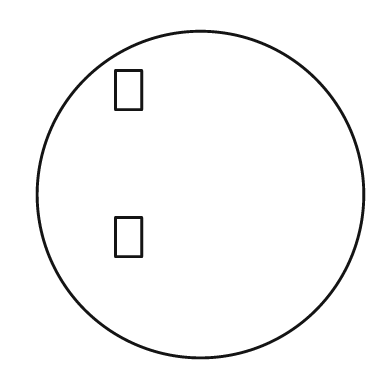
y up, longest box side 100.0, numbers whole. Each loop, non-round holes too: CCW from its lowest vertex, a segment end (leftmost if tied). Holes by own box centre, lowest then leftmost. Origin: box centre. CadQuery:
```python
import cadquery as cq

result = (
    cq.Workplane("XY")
    .moveTo(0.0, 0.0)
    .circle(50.0)
    .moveTo(-26.0, -19.0)
    .lineTo(-18.0, -19.0)
    .lineTo(-18.0, -7.0)
    .lineTo(-26.0, -7.0)
    .close()
    .moveTo(-26.0, 26.0)
    .lineTo(-18.0, 26.0)
    .lineTo(-18.0, 38.0)
    .lineTo(-26.0, 38.0)
    .close()
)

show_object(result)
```